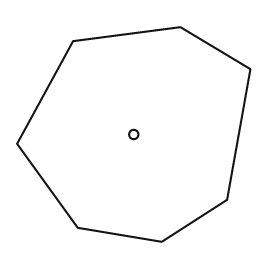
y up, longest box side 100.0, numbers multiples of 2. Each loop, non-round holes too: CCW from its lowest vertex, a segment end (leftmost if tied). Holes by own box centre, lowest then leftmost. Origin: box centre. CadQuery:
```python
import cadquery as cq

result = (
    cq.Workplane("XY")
    .moveTo(12.0, -46.0)
    .lineTo(40.0, -28.0)
    .lineTo(50.0, 28.0)
    .lineTo(20.0, 46.0)
    .lineTo(-26.0, 40.0)
    .lineTo(-50.0, -4.0)
    .lineTo(-24.0, -40.0)
    .close()
    .moveTo(0.0, 0.0)
    .circle(2.0)
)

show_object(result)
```